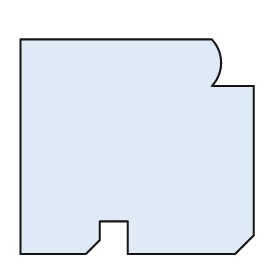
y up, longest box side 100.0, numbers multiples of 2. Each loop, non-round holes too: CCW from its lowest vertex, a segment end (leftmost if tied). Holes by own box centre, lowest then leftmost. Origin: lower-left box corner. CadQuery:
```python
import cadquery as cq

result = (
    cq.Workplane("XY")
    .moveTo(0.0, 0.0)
    .lineTo(28.0, 0.0)
    .lineTo(34.0, 6.0)
    .lineTo(34.0, 14.0)
    .lineTo(46.0, 14.0)
    .lineTo(46.0, 0.0)
    .lineTo(92.0, 0.0)
    .lineTo(100.0, 8.0)
    .lineTo(100.0, 72.0)
    .lineTo(82.0, 72.0)
    .threePointArc((86.0, 82.0), (82.0, 92.0))
    .lineTo(0.0, 92.0)
    .close()
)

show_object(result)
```